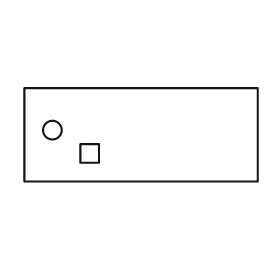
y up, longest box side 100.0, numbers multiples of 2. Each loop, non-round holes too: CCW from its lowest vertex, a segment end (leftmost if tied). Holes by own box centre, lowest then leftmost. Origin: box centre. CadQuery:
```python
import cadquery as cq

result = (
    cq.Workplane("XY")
    .moveTo(-50.0, -20.0)
    .lineTo(50.0, -20.0)
    .lineTo(50.0, 20.0)
    .lineTo(-50.0, 20.0)
    .close()
    .moveTo(-26.0, -12.0)
    .lineTo(-18.0, -12.0)
    .lineTo(-18.0, -4.0)
    .lineTo(-26.0, -4.0)
    .close()
    .moveTo(-38.0, 2.0)
    .circle(4.0)
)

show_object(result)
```